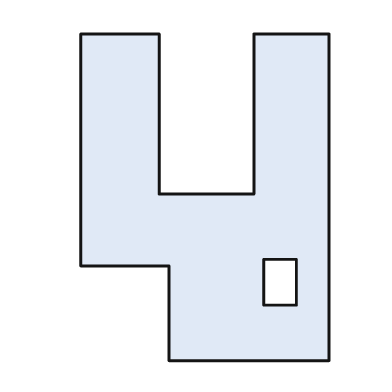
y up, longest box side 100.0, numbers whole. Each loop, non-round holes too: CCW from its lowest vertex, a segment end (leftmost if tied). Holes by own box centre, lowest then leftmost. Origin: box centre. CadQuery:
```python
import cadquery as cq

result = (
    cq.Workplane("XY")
    .moveTo(-11.0, -50.0)
    .lineTo(38.0, -50.0)
    .lineTo(38.0, 50.0)
    .lineTo(15.0, 50.0)
    .lineTo(15.0, 1.0)
    .lineTo(-14.0, 1.0)
    .lineTo(-14.0, 50.0)
    .lineTo(-38.0, 50.0)
    .lineTo(-38.0, -21.0)
    .lineTo(-11.0, -21.0)
    .close()
    .moveTo(18.0, -33.0)
    .lineTo(28.0, -33.0)
    .lineTo(28.0, -19.0)
    .lineTo(18.0, -19.0)
    .close()
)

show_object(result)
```